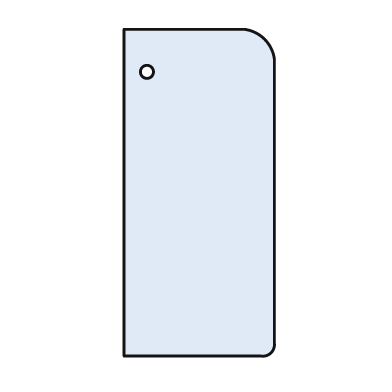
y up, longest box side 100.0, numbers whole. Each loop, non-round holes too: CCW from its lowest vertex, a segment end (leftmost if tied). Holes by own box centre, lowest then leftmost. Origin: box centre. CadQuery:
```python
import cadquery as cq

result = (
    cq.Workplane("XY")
    .moveTo(-23.0, -50.0)
    .lineTo(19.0, -50.0)
    .threePointArc((22.0, -49.0), (23.0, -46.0))
    .lineTo(23.0, 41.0)
    .threePointArc((20.0, 47.0), (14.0, 50.0))
    .lineTo(-23.0, 50.0)
    .close()
    .moveTo(-16.0, 37.0)
    .circle(2.0)
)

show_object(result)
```